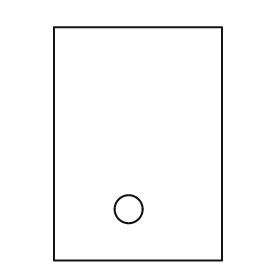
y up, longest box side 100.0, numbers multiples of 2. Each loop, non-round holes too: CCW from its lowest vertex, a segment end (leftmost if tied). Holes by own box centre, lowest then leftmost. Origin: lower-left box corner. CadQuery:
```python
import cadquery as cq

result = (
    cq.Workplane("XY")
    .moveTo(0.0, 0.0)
    .lineTo(72.0, 0.0)
    .lineTo(72.0, 100.0)
    .lineTo(0.0, 100.0)
    .close()
    .moveTo(32.0, 22.0)
    .circle(6.0)
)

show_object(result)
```